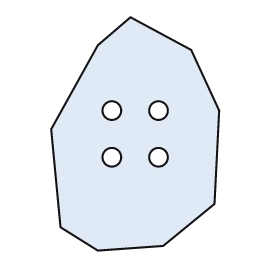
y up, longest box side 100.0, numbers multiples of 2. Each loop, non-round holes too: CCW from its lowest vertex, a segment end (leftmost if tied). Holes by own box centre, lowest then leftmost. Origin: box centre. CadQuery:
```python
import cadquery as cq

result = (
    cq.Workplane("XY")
    .moveTo(-16.0, -50.0)
    .lineTo(12.0, -48.0)
    .lineTo(34.0, -30.0)
    .lineTo(36.0, 10.0)
    .lineTo(24.0, 36.0)
    .lineTo(-2.0, 50.0)
    .lineTo(-16.0, 38.0)
    .lineTo(-36.0, 2.0)
    .lineTo(-32.0, -40.0)
    .close()
    .moveTo(-10.0, -10.0)
    .circle(4.0)
    .moveTo(10.0, -10.0)
    .circle(4.0)
    .moveTo(-10.0, 10.0)
    .circle(4.0)
    .moveTo(10.0, 10.0)
    .circle(4.0)
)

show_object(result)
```